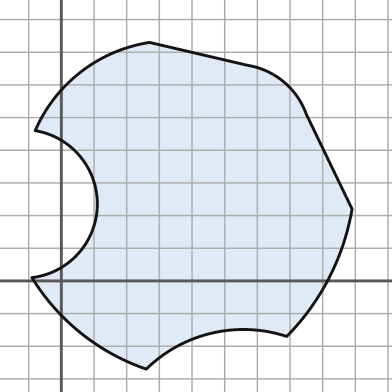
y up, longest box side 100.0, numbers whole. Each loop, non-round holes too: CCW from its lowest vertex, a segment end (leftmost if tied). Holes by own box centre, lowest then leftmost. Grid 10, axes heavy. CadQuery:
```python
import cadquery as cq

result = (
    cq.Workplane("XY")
    .moveTo(26.0, -27.0)
    .threePointArc((46.0, -16.0), (69.0, -17.0))
    .threePointArc((82.0, 1.0), (89.0, 22.0))
    .lineTo(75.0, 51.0)
    .threePointArc((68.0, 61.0), (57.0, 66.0))
    .lineTo(27.0, 73.0)
    .threePointArc((6.0, 64.0), (-8.0, 46.0))
    .threePointArc((11.0, 23.0), (-9.0, 1.0))
    .threePointArc((6.0, -16.0), (26.0, -27.0))
    .close()
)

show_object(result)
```